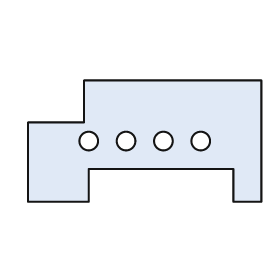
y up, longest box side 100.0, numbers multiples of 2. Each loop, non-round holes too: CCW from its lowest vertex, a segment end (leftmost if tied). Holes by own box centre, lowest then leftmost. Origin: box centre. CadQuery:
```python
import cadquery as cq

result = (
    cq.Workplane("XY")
    .moveTo(-50.0, -26.0)
    .lineTo(-24.0, -26.0)
    .lineTo(-24.0, -12.0)
    .lineTo(38.0, -12.0)
    .lineTo(38.0, -26.0)
    .lineTo(50.0, -26.0)
    .lineTo(50.0, 26.0)
    .lineTo(-26.0, 26.0)
    .lineTo(-26.0, 8.0)
    .lineTo(-50.0, 8.0)
    .close()
    .moveTo(-24.0, 0.0)
    .circle(4.0)
    .moveTo(-8.0, 0.0)
    .circle(4.0)
    .moveTo(8.0, 0.0)
    .circle(4.0)
    .moveTo(24.0, 0.0)
    .circle(4.0)
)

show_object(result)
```